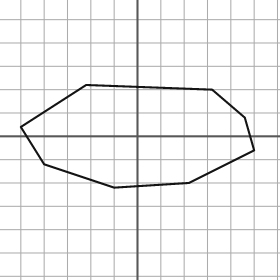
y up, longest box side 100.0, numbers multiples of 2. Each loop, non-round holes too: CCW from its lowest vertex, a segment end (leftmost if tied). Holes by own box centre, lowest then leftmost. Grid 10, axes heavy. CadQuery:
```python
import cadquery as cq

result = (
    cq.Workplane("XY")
    .moveTo(-10.0, -22.0)
    .lineTo(22.0, -20.0)
    .lineTo(50.0, -6.0)
    .lineTo(46.0, 8.0)
    .lineTo(32.0, 20.0)
    .lineTo(-22.0, 22.0)
    .lineTo(-50.0, 4.0)
    .lineTo(-40.0, -12.0)
    .close()
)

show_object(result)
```